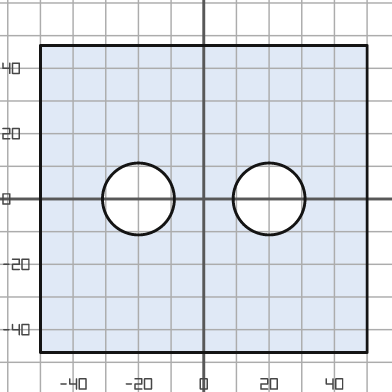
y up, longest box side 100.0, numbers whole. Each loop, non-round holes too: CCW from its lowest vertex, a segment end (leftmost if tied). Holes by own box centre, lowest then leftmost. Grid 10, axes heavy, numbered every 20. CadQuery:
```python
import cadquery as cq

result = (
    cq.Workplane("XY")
    .moveTo(-50.0, -47.0)
    .lineTo(50.0, -47.0)
    .lineTo(50.0, 47.0)
    .lineTo(-50.0, 47.0)
    .close()
    .moveTo(-20.0, 0.0)
    .circle(11.0)
    .moveTo(20.0, 0.0)
    .circle(11.0)
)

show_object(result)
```